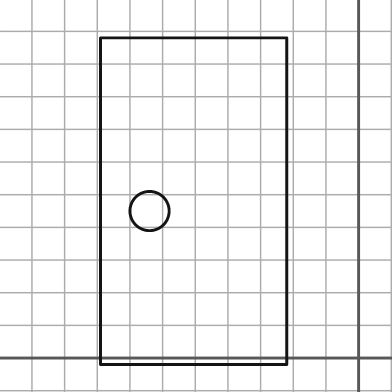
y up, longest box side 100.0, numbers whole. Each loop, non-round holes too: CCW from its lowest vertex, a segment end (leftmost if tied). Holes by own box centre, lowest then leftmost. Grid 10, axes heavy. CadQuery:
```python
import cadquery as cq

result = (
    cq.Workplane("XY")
    .moveTo(-79.0, -2.0)
    .lineTo(-22.0, -2.0)
    .lineTo(-22.0, 98.0)
    .lineTo(-79.0, 98.0)
    .close()
    .moveTo(-64.0, 45.0)
    .circle(6.0)
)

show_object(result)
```